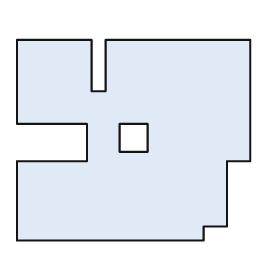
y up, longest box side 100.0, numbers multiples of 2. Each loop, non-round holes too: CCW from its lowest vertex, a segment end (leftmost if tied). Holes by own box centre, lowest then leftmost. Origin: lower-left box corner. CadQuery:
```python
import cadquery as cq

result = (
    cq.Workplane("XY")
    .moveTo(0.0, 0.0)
    .lineTo(80.0, 0.0)
    .lineTo(80.0, 6.0)
    .lineTo(90.0, 6.0)
    .lineTo(90.0, 34.0)
    .lineTo(100.0, 34.0)
    .lineTo(100.0, 86.0)
    .lineTo(38.0, 86.0)
    .lineTo(38.0, 64.0)
    .lineTo(32.0, 64.0)
    .lineTo(32.0, 86.0)
    .lineTo(0.0, 86.0)
    .lineTo(0.0, 50.0)
    .lineTo(30.0, 50.0)
    .lineTo(30.0, 34.0)
    .lineTo(0.0, 34.0)
    .close()
    .moveTo(44.0, 38.0)
    .lineTo(56.0, 38.0)
    .lineTo(56.0, 50.0)
    .lineTo(44.0, 50.0)
    .close()
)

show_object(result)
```